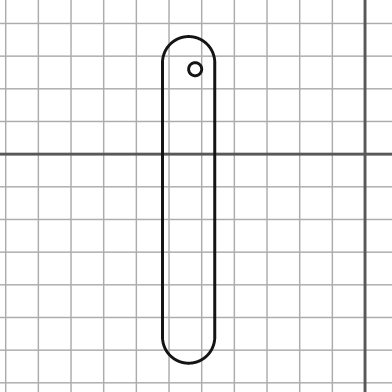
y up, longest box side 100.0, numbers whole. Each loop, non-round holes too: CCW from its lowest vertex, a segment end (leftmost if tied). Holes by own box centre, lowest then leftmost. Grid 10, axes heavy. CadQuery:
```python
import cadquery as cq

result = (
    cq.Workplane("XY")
    .moveTo(-62.0, -56.0)
    .threePointArc((-54.0, -64.0), (-46.0, -56.0))
    .lineTo(-46.0, 28.0)
    .threePointArc((-54.0, 36.0), (-62.0, 28.0))
    .close()
    .moveTo(-52.0, 26.0)
    .circle(2.0)
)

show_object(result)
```